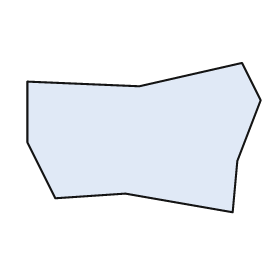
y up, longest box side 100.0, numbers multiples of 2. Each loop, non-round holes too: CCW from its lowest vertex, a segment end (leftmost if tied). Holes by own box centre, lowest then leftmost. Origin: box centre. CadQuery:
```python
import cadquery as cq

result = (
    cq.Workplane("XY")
    .moveTo(38.0, -32.0)
    .lineTo(40.0, -10.0)
    .lineTo(50.0, 16.0)
    .lineTo(42.0, 32.0)
    .lineTo(-2.0, 22.0)
    .lineTo(-50.0, 24.0)
    .lineTo(-50.0, -2.0)
    .lineTo(-38.0, -26.0)
    .lineTo(-8.0, -24.0)
    .close()
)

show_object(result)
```